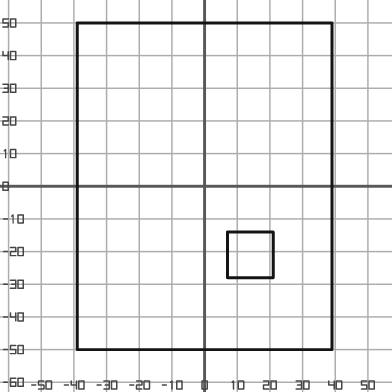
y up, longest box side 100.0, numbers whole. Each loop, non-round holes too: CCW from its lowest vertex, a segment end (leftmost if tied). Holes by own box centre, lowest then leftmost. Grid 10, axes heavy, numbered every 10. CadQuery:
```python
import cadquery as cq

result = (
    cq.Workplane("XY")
    .moveTo(-39.0, -50.0)
    .lineTo(39.0, -50.0)
    .lineTo(39.0, 50.0)
    .lineTo(-39.0, 50.0)
    .close()
    .moveTo(7.0, -28.0)
    .lineTo(21.0, -28.0)
    .lineTo(21.0, -14.0)
    .lineTo(7.0, -14.0)
    .close()
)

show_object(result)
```